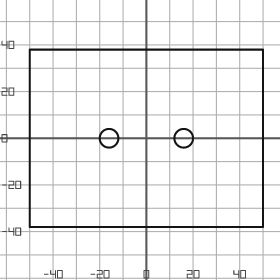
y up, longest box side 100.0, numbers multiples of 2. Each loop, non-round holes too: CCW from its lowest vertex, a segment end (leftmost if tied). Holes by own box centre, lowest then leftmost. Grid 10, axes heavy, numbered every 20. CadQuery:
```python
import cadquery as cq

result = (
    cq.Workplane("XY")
    .moveTo(-50.0, -38.0)
    .lineTo(50.0, -38.0)
    .lineTo(50.0, 38.0)
    .lineTo(-50.0, 38.0)
    .close()
    .moveTo(-16.0, 0.0)
    .circle(4.0)
    .moveTo(16.0, 0.0)
    .circle(4.0)
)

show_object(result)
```